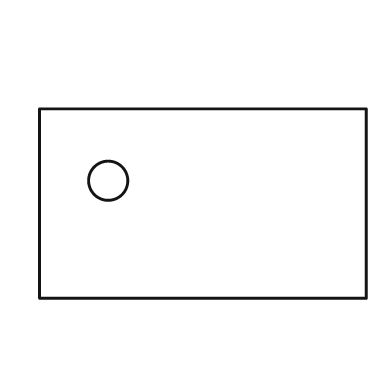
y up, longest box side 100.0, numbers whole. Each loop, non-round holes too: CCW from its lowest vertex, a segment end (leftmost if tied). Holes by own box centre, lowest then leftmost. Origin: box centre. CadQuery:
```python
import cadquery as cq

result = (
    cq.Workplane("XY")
    .moveTo(-50.0, -29.0)
    .lineTo(50.0, -29.0)
    .lineTo(50.0, 29.0)
    .lineTo(-50.0, 29.0)
    .close()
    .moveTo(-29.0, 7.0)
    .circle(6.0)
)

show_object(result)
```